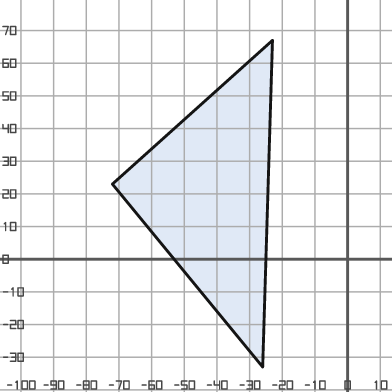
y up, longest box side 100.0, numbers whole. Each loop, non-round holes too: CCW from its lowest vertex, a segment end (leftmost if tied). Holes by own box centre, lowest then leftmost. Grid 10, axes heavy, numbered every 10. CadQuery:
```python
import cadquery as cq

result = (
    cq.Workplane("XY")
    .moveTo(-26.0, -33.0)
    .lineTo(-23.0, 67.0)
    .lineTo(-72.0, 23.0)
    .close()
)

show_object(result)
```